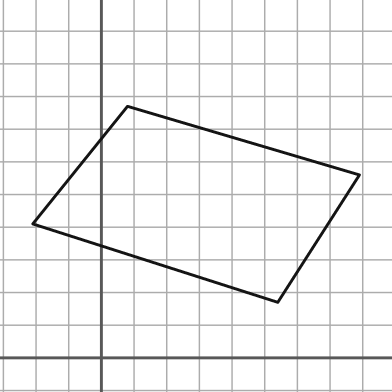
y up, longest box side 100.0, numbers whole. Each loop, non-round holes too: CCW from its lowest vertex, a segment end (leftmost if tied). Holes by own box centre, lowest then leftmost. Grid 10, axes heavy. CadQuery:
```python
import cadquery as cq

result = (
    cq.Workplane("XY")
    .moveTo(54.0, 17.0)
    .lineTo(79.0, 56.0)
    .lineTo(8.0, 77.0)
    .lineTo(-21.0, 41.0)
    .close()
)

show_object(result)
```